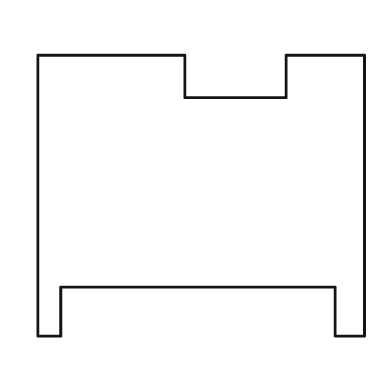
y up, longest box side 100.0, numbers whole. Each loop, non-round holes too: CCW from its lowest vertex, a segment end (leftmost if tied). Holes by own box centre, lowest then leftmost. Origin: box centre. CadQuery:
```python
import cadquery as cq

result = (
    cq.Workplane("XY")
    .moveTo(-50.0, -43.0)
    .lineTo(-43.0, -43.0)
    .lineTo(-43.0, -28.0)
    .lineTo(41.0, -28.0)
    .lineTo(41.0, -43.0)
    .lineTo(50.0, -43.0)
    .lineTo(50.0, 43.0)
    .lineTo(26.0, 43.0)
    .lineTo(26.0, 30.0)
    .lineTo(-5.0, 30.0)
    .lineTo(-5.0, 43.0)
    .lineTo(-50.0, 43.0)
    .close()
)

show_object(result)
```